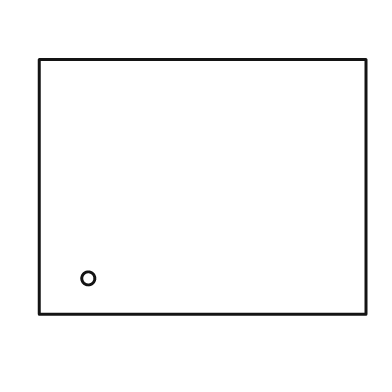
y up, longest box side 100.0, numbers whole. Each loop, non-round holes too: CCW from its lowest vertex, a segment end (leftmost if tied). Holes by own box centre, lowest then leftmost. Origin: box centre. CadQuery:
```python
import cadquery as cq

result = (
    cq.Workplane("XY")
    .moveTo(-50.0, -39.0)
    .lineTo(50.0, -39.0)
    .lineTo(50.0, 39.0)
    .lineTo(-50.0, 39.0)
    .close()
    .moveTo(-35.0, -28.0)
    .circle(2.0)
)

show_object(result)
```